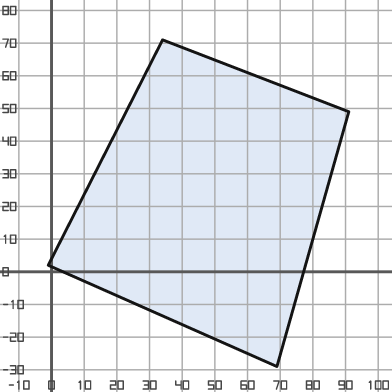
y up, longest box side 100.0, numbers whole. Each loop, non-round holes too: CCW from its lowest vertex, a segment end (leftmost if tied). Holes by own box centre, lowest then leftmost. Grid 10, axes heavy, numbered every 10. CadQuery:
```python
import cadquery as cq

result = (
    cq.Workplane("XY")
    .moveTo(69.0, -29.0)
    .lineTo(91.0, 49.0)
    .lineTo(34.0, 71.0)
    .lineTo(-1.0, 2.0)
    .close()
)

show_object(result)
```